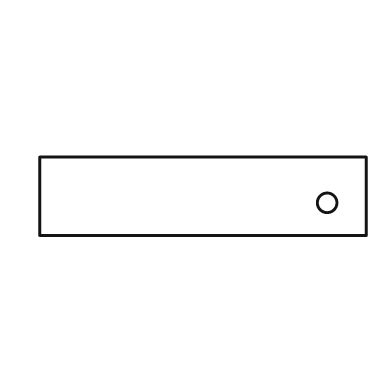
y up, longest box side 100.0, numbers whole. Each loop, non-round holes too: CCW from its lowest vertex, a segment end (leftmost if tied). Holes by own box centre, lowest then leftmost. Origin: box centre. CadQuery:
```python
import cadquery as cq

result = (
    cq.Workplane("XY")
    .moveTo(-50.0, -12.0)
    .lineTo(50.0, -12.0)
    .lineTo(50.0, 12.0)
    .lineTo(-50.0, 12.0)
    .close()
    .moveTo(38.0, -2.0)
    .circle(3.0)
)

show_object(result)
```